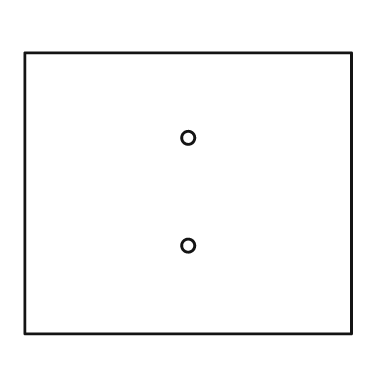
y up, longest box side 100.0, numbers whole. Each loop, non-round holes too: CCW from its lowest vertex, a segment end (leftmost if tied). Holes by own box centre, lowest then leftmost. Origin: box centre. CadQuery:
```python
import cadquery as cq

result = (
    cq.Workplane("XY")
    .moveTo(-50.0, -43.0)
    .lineTo(50.0, -43.0)
    .lineTo(50.0, 43.0)
    .lineTo(-50.0, 43.0)
    .close()
    .moveTo(0.0, -16.0)
    .circle(2.0)
    .moveTo(0.0, 17.0)
    .circle(2.0)
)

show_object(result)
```